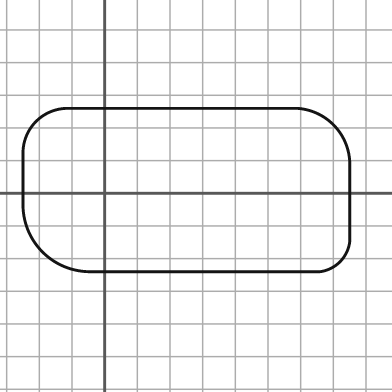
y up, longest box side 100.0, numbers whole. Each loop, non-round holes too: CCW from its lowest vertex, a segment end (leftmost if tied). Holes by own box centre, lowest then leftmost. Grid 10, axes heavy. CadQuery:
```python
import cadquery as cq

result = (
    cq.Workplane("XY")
    .moveTo(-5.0, -24.0)
    .lineTo(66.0, -24.0)
    .threePointArc((72.0, -21.0), (75.0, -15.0))
    .lineTo(75.0, 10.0)
    .threePointArc((70.0, 21.0), (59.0, 26.0))
    .lineTo(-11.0, 26.0)
    .threePointArc((-21.0, 22.0), (-25.0, 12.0))
    .lineTo(-25.0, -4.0)
    .threePointArc((-19.0, -18.0), (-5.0, -24.0))
    .close()
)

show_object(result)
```